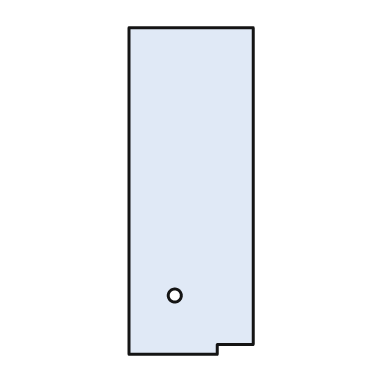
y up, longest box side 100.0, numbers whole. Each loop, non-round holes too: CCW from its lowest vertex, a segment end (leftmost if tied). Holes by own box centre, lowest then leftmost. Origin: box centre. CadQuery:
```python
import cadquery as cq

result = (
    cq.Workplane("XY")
    .moveTo(-19.0, -50.0)
    .lineTo(8.0, -50.0)
    .lineTo(8.0, -47.0)
    .lineTo(19.0, -47.0)
    .lineTo(19.0, 50.0)
    .lineTo(-19.0, 50.0)
    .close()
    .moveTo(-5.0, -32.0)
    .circle(2.0)
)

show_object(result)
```